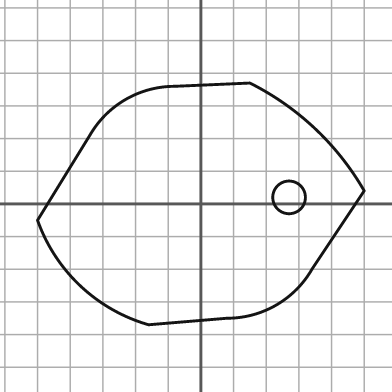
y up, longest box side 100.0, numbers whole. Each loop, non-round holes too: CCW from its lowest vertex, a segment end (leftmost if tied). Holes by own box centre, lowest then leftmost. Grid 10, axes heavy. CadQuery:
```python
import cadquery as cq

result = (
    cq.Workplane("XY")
    .moveTo(-16.0, -37.0)
    .lineTo(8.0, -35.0)
    .threePointArc((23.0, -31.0), (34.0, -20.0))
    .lineTo(50.0, 4.0)
    .threePointArc((35.0, 23.0), (15.0, 37.0))
    .lineTo(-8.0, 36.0)
    .threePointArc((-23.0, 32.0), (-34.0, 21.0))
    .lineTo(-50.0, -5.0)
    .threePointArc((-37.0, -25.0), (-16.0, -37.0))
    .close()
    .moveTo(27.0, 2.0)
    .circle(5.0)
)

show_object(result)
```